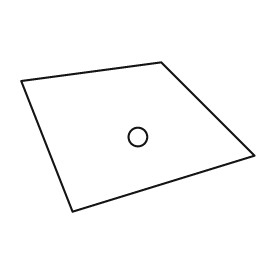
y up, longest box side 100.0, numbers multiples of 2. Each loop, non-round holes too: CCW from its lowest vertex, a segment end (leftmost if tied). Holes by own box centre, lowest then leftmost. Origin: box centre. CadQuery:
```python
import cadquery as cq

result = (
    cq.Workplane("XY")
    .moveTo(-28.0, -32.0)
    .lineTo(50.0, -8.0)
    .lineTo(10.0, 32.0)
    .lineTo(-50.0, 24.0)
    .close()
    .moveTo(0.0, 0.0)
    .circle(4.0)
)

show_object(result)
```